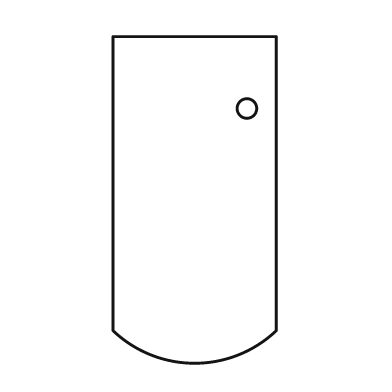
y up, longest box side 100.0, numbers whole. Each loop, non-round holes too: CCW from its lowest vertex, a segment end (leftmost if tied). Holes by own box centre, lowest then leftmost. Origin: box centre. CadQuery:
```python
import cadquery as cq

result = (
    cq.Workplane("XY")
    .moveTo(-25.0, -40.0)
    .threePointArc((0.0, -50.0), (25.0, -40.0))
    .lineTo(25.0, 50.0)
    .lineTo(-25.0, 50.0)
    .close()
    .moveTo(16.0, 28.0)
    .circle(3.0)
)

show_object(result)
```